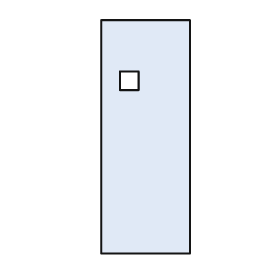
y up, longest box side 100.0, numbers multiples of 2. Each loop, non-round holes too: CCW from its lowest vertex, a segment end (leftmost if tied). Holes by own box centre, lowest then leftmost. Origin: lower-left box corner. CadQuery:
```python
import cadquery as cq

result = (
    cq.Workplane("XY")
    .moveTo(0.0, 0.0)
    .lineTo(38.0, 0.0)
    .lineTo(38.0, 100.0)
    .lineTo(0.0, 100.0)
    .close()
    .moveTo(8.0, 70.0)
    .lineTo(16.0, 70.0)
    .lineTo(16.0, 78.0)
    .lineTo(8.0, 78.0)
    .close()
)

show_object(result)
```